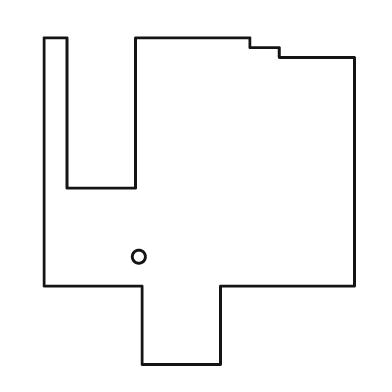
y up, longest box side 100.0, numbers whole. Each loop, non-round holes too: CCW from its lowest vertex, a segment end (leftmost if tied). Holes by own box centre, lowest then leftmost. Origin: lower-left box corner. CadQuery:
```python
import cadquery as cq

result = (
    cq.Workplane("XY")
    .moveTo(30.0, 0.0)
    .lineTo(54.0, 0.0)
    .lineTo(54.0, 24.0)
    .lineTo(95.0, 24.0)
    .lineTo(95.0, 94.0)
    .lineTo(72.0, 94.0)
    .lineTo(72.0, 97.0)
    .lineTo(63.0, 97.0)
    .lineTo(63.0, 100.0)
    .lineTo(28.0, 100.0)
    .lineTo(28.0, 54.0)
    .lineTo(7.0, 54.0)
    .lineTo(7.0, 100.0)
    .lineTo(0.0, 100.0)
    .lineTo(0.0, 24.0)
    .lineTo(30.0, 24.0)
    .close()
    .moveTo(29.0, 33.0)
    .circle(2.0)
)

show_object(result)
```